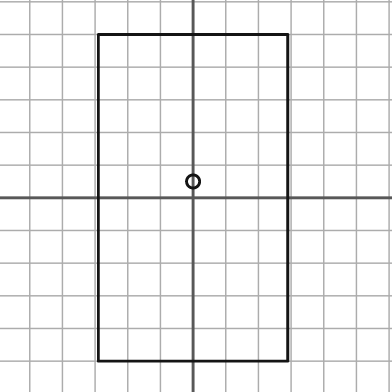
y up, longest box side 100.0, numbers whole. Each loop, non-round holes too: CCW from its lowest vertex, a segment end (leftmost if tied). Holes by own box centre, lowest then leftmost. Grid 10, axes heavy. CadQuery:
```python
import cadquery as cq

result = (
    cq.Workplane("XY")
    .moveTo(-29.0, -50.0)
    .lineTo(29.0, -50.0)
    .lineTo(29.0, 50.0)
    .lineTo(-29.0, 50.0)
    .close()
    .moveTo(0.0, 5.0)
    .circle(2.0)
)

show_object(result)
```